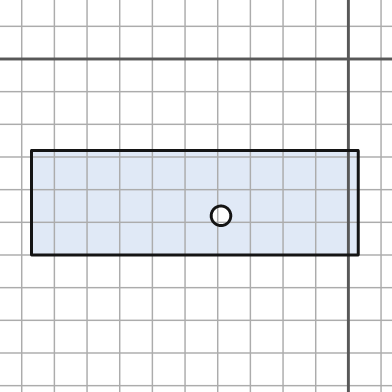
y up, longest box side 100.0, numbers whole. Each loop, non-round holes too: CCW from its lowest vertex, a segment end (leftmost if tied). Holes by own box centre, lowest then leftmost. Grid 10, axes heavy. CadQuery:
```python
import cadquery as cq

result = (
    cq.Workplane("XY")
    .moveTo(-97.0, -60.0)
    .lineTo(3.0, -60.0)
    .lineTo(3.0, -28.0)
    .lineTo(-97.0, -28.0)
    .close()
    .moveTo(-39.0, -48.0)
    .circle(3.0)
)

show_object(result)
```